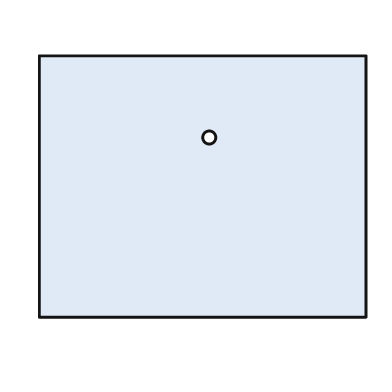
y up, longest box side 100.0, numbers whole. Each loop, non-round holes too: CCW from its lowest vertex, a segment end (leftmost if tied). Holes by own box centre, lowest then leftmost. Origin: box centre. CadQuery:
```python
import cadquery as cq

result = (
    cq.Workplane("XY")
    .moveTo(-50.0, -40.0)
    .lineTo(50.0, -40.0)
    .lineTo(50.0, 40.0)
    .lineTo(-50.0, 40.0)
    .close()
    .moveTo(2.0, 15.0)
    .circle(2.0)
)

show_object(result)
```